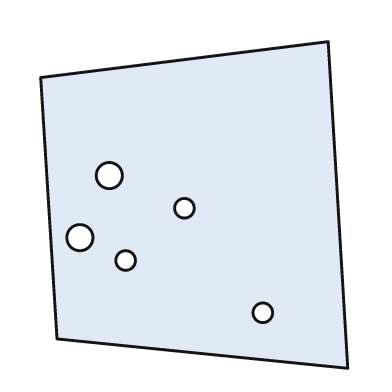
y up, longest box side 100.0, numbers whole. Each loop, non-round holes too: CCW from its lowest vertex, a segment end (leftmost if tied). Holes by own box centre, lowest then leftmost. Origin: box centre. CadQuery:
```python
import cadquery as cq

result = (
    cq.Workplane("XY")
    .moveTo(47.0, -50.0)
    .lineTo(41.0, 50.0)
    .lineTo(-47.0, 39.0)
    .lineTo(-42.0, -41.0)
    .close()
    .moveTo(21.0, -33.0)
    .circle(3.0)
    .moveTo(-21.0, -17.0)
    .circle(3.0)
    .moveTo(-35.0, -10.0)
    .circle(4.0)
    .moveTo(-3.0, -1.0)
    .circle(3.0)
    .moveTo(-26.0, 9.0)
    .circle(4.0)
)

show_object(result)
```